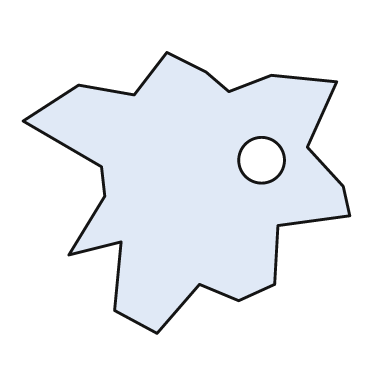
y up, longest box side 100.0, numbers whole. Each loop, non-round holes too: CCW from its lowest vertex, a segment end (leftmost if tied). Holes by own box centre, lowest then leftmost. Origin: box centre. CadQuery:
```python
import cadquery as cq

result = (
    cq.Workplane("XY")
    .moveTo(-9.0, -43.0)
    .lineTo(4.0, -28.0)
    .lineTo(16.0, -33.0)
    .lineTo(27.0, -28.0)
    .lineTo(28.0, -10.0)
    .lineTo(50.0, -7.0)
    .lineTo(48.0, 2.0)
    .lineTo(37.0, 14.0)
    .lineTo(46.0, 34.0)
    .lineTo(26.0, 36.0)
    .lineTo(13.0, 31.0)
    .lineTo(6.0, 37.0)
    .lineTo(-6.0, 43.0)
    .lineTo(-16.0, 30.0)
    .lineTo(-33.0, 33.0)
    .lineTo(-50.0, 22.0)
    .lineTo(-26.0, 8.0)
    .lineTo(-25.0, -1.0)
    .lineTo(-36.0, -19.0)
    .lineTo(-20.0, -15.0)
    .lineTo(-22.0, -36.0)
    .close()
    .moveTo(23.0, 10.0)
    .circle(7.0)
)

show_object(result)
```